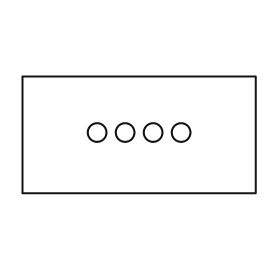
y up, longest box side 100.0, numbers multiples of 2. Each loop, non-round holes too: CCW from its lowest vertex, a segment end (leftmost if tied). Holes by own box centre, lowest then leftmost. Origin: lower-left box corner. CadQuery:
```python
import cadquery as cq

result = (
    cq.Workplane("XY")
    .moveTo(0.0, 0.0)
    .lineTo(100.0, 0.0)
    .lineTo(100.0, 50.0)
    .lineTo(0.0, 50.0)
    .close()
    .moveTo(32.0, 26.0)
    .circle(4.0)
    .moveTo(44.0, 26.0)
    .circle(4.0)
    .moveTo(56.0, 26.0)
    .circle(4.0)
    .moveTo(68.0, 26.0)
    .circle(4.0)
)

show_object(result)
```